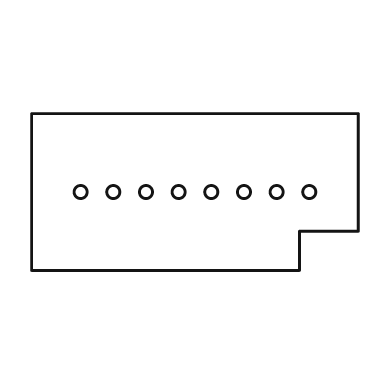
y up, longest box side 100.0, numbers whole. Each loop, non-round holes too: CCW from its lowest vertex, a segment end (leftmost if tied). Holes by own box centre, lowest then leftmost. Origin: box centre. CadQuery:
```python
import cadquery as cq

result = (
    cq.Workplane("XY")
    .moveTo(-50.0, -24.0)
    .lineTo(32.0, -24.0)
    .lineTo(32.0, -12.0)
    .lineTo(50.0, -12.0)
    .lineTo(50.0, 24.0)
    .lineTo(-50.0, 24.0)
    .close()
    .moveTo(-35.0, 0.0)
    .circle(2.0)
    .moveTo(-25.0, 0.0)
    .circle(2.0)
    .moveTo(-15.0, 0.0)
    .circle(2.0)
    .moveTo(-5.0, 0.0)
    .circle(2.0)
    .moveTo(5.0, 0.0)
    .circle(2.0)
    .moveTo(15.0, 0.0)
    .circle(2.0)
    .moveTo(25.0, 0.0)
    .circle(2.0)
    .moveTo(35.0, 0.0)
    .circle(2.0)
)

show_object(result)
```